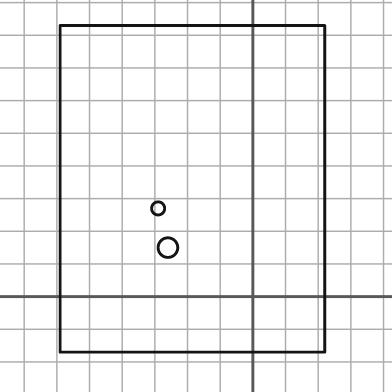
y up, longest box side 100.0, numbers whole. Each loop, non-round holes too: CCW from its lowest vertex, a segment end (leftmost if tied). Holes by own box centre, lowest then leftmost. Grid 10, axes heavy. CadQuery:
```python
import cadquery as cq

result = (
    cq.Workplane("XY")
    .moveTo(-59.0, -17.0)
    .lineTo(22.0, -17.0)
    .lineTo(22.0, 83.0)
    .lineTo(-59.0, 83.0)
    .close()
    .moveTo(-26.0, 15.0)
    .circle(3.0)
    .moveTo(-29.0, 27.0)
    .circle(2.0)
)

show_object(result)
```